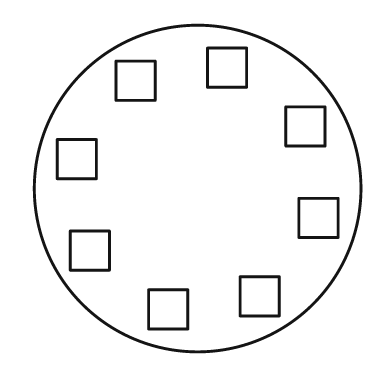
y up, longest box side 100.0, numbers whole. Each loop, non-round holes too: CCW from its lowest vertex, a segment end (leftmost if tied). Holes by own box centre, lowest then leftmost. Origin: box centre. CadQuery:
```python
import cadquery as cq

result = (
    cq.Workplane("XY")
    .moveTo(0.0, 0.0)
    .circle(50.0)
    .moveTo(-15.0, -43.0)
    .lineTo(-3.0, -43.0)
    .lineTo(-3.0, -31.0)
    .lineTo(-15.0, -31.0)
    .close()
    .moveTo(13.0, -39.0)
    .lineTo(25.0, -39.0)
    .lineTo(25.0, -27.0)
    .lineTo(13.0, -27.0)
    .close()
    .moveTo(-39.0, -25.0)
    .lineTo(-27.0, -25.0)
    .lineTo(-27.0, -13.0)
    .lineTo(-39.0, -13.0)
    .close()
    .moveTo(31.0, -15.0)
    .lineTo(43.0, -15.0)
    .lineTo(43.0, -3.0)
    .lineTo(31.0, -3.0)
    .close()
    .moveTo(-43.0, 3.0)
    .lineTo(-31.0, 3.0)
    .lineTo(-31.0, 15.0)
    .lineTo(-43.0, 15.0)
    .close()
    .moveTo(27.0, 13.0)
    .lineTo(39.0, 13.0)
    .lineTo(39.0, 25.0)
    .lineTo(27.0, 25.0)
    .close()
    .moveTo(-25.0, 27.0)
    .lineTo(-13.0, 27.0)
    .lineTo(-13.0, 39.0)
    .lineTo(-25.0, 39.0)
    .close()
    .moveTo(3.0, 31.0)
    .lineTo(15.0, 31.0)
    .lineTo(15.0, 43.0)
    .lineTo(3.0, 43.0)
    .close()
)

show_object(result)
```